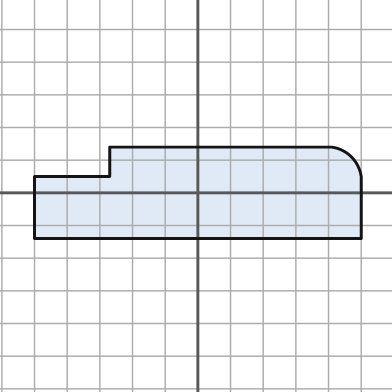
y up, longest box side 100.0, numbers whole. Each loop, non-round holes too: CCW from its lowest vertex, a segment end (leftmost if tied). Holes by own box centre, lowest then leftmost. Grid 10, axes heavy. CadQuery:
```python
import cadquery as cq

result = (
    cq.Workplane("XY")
    .moveTo(-50.0, -14.0)
    .lineTo(50.0, -14.0)
    .lineTo(50.0, 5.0)
    .threePointArc((47.0, 11.0), (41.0, 14.0))
    .lineTo(-27.0, 14.0)
    .lineTo(-27.0, 5.0)
    .lineTo(-50.0, 5.0)
    .close()
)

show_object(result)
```